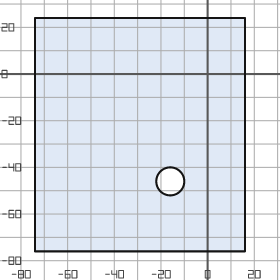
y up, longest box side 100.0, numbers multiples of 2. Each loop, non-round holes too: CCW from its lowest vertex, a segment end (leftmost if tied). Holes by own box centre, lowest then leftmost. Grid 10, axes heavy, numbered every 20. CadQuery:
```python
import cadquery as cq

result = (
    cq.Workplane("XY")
    .moveTo(-74.0, -76.0)
    .lineTo(16.0, -76.0)
    .lineTo(16.0, 24.0)
    .lineTo(-74.0, 24.0)
    .close()
    .moveTo(-16.0, -46.0)
    .circle(6.0)
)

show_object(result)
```